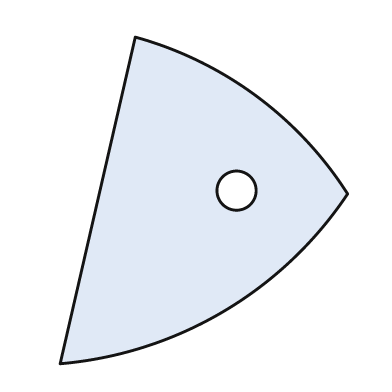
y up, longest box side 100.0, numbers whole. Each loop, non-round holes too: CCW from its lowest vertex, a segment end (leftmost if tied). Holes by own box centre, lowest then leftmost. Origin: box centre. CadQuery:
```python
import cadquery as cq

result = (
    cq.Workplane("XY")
    .moveTo(-44.0, -50.0)
    .threePointArc((6.0, -34.0), (44.0, 2.0))
    .threePointArc((16.0, 32.0), (-21.0, 50.0))
    .close()
    .moveTo(10.0, 3.0)
    .circle(6.0)
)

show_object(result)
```